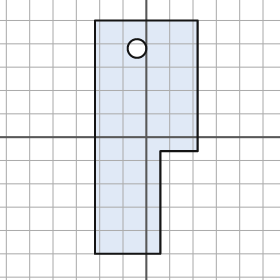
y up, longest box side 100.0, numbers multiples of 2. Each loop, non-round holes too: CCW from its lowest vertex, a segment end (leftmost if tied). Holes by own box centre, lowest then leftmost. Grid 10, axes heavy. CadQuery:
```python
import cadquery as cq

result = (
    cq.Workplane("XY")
    .moveTo(-22.0, -50.0)
    .lineTo(6.0, -50.0)
    .lineTo(6.0, -6.0)
    .lineTo(22.0, -6.0)
    .lineTo(22.0, 50.0)
    .lineTo(-22.0, 50.0)
    .close()
    .moveTo(-4.0, 38.0)
    .circle(4.0)
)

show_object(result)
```